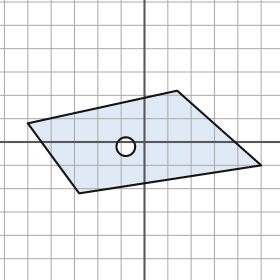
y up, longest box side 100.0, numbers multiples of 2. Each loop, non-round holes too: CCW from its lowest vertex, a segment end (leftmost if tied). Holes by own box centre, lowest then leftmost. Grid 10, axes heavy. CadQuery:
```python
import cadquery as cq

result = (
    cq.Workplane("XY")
    .moveTo(-28.0, -22.0)
    .lineTo(50.0, -10.0)
    .lineTo(14.0, 22.0)
    .lineTo(-50.0, 8.0)
    .close()
    .moveTo(-8.0, -2.0)
    .circle(4.0)
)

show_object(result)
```